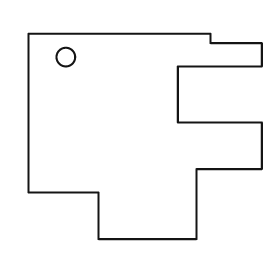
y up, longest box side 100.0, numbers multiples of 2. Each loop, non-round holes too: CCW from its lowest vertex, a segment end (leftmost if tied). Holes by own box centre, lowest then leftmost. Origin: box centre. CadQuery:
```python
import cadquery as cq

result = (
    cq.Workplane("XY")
    .moveTo(-20.0, -44.0)
    .lineTo(22.0, -44.0)
    .lineTo(22.0, -14.0)
    .lineTo(50.0, -14.0)
    .lineTo(50.0, 6.0)
    .lineTo(14.0, 6.0)
    .lineTo(14.0, 30.0)
    .lineTo(50.0, 30.0)
    .lineTo(50.0, 40.0)
    .lineTo(28.0, 40.0)
    .lineTo(28.0, 44.0)
    .lineTo(-50.0, 44.0)
    .lineTo(-50.0, -24.0)
    .lineTo(-20.0, -24.0)
    .close()
    .moveTo(-34.0, 34.0)
    .circle(4.0)
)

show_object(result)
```